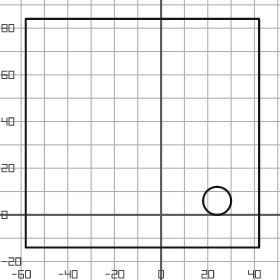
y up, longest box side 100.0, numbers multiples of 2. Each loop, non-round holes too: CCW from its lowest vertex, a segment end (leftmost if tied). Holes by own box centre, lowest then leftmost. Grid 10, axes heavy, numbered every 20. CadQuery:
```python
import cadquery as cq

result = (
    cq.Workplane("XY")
    .moveTo(-58.0, -14.0)
    .lineTo(42.0, -14.0)
    .lineTo(42.0, 84.0)
    .lineTo(-58.0, 84.0)
    .close()
    .moveTo(24.0, 6.0)
    .circle(6.0)
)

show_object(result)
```